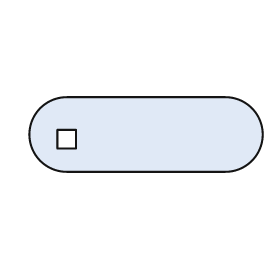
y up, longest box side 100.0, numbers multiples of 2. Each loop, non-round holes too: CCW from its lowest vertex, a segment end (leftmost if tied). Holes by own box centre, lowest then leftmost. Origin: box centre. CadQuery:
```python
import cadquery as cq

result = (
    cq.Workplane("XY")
    .moveTo(-34.0, -16.0)
    .lineTo(34.0, -16.0)
    .threePointArc((50.0, 0.0), (34.0, 16.0))
    .lineTo(-34.0, 16.0)
    .threePointArc((-50.0, 0.0), (-34.0, -16.0))
    .close()
    .moveTo(-38.0, -6.0)
    .lineTo(-30.0, -6.0)
    .lineTo(-30.0, 2.0)
    .lineTo(-38.0, 2.0)
    .close()
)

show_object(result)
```